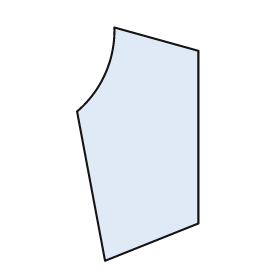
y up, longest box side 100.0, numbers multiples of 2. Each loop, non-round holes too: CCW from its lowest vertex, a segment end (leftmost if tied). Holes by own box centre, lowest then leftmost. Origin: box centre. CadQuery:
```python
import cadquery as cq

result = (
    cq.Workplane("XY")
    .moveTo(-14.0, -50.0)
    .lineTo(26.0, -34.0)
    .lineTo(26.0, 40.0)
    .lineTo(-10.0, 50.0)
    .threePointArc((-14.0, 30.0), (-26.0, 14.0))
    .close()
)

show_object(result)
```